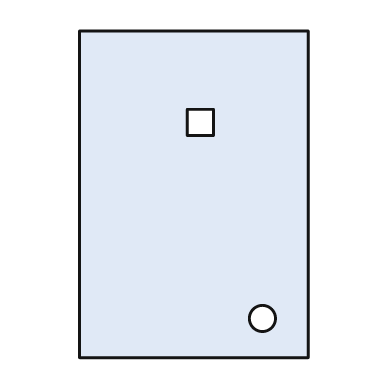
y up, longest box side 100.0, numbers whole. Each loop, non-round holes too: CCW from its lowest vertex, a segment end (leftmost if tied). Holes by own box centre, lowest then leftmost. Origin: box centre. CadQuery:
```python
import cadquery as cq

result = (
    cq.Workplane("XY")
    .moveTo(-35.0, -50.0)
    .lineTo(35.0, -50.0)
    .lineTo(35.0, 50.0)
    .lineTo(-35.0, 50.0)
    .close()
    .moveTo(21.0, -38.0)
    .circle(4.0)
    .moveTo(-2.0, 18.0)
    .lineTo(6.0, 18.0)
    .lineTo(6.0, 26.0)
    .lineTo(-2.0, 26.0)
    .close()
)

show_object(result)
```